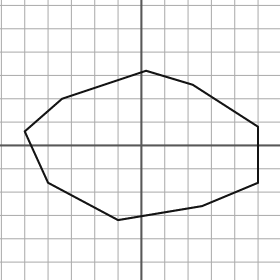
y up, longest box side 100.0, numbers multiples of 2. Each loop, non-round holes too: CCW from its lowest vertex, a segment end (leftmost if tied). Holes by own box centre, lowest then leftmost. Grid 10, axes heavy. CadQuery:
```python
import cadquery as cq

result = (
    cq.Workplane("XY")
    .moveTo(-10.0, -32.0)
    .lineTo(26.0, -26.0)
    .lineTo(50.0, -16.0)
    .lineTo(50.0, 8.0)
    .lineTo(22.0, 26.0)
    .lineTo(2.0, 32.0)
    .lineTo(-34.0, 20.0)
    .lineTo(-50.0, 6.0)
    .lineTo(-40.0, -16.0)
    .close()
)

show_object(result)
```